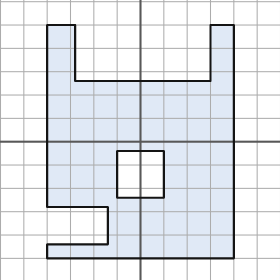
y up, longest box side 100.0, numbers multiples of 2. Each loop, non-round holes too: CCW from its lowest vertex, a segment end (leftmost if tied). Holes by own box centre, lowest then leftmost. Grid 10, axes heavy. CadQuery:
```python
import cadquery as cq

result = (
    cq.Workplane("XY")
    .moveTo(-40.0, -50.0)
    .lineTo(40.0, -50.0)
    .lineTo(40.0, 50.0)
    .lineTo(30.0, 50.0)
    .lineTo(30.0, 26.0)
    .lineTo(-28.0, 26.0)
    .lineTo(-28.0, 50.0)
    .lineTo(-40.0, 50.0)
    .lineTo(-40.0, -28.0)
    .lineTo(-14.0, -28.0)
    .lineTo(-14.0, -44.0)
    .lineTo(-40.0, -44.0)
    .close()
    .moveTo(-10.0, -24.0)
    .lineTo(10.0, -24.0)
    .lineTo(10.0, -4.0)
    .lineTo(-10.0, -4.0)
    .close()
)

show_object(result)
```